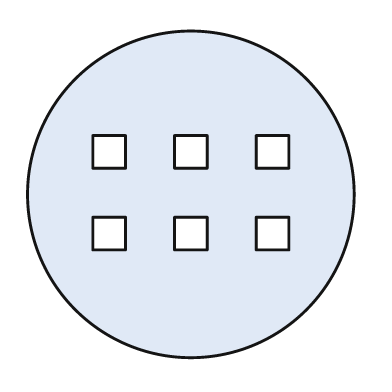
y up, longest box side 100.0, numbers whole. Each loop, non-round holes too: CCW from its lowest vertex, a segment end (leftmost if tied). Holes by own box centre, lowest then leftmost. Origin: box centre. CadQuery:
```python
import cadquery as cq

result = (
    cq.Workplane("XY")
    .moveTo(0.0, 0.0)
    .circle(50.0)
    .moveTo(-30.0, -17.0)
    .lineTo(-20.0, -17.0)
    .lineTo(-20.0, -7.0)
    .lineTo(-30.0, -7.0)
    .close()
    .moveTo(-5.0, -17.0)
    .lineTo(5.0, -17.0)
    .lineTo(5.0, -7.0)
    .lineTo(-5.0, -7.0)
    .close()
    .moveTo(20.0, -17.0)
    .lineTo(30.0, -17.0)
    .lineTo(30.0, -7.0)
    .lineTo(20.0, -7.0)
    .close()
    .moveTo(-30.0, 8.0)
    .lineTo(-20.0, 8.0)
    .lineTo(-20.0, 18.0)
    .lineTo(-30.0, 18.0)
    .close()
    .moveTo(-5.0, 8.0)
    .lineTo(5.0, 8.0)
    .lineTo(5.0, 18.0)
    .lineTo(-5.0, 18.0)
    .close()
    .moveTo(20.0, 8.0)
    .lineTo(30.0, 8.0)
    .lineTo(30.0, 18.0)
    .lineTo(20.0, 18.0)
    .close()
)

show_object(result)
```